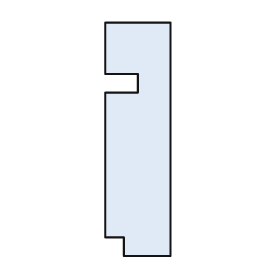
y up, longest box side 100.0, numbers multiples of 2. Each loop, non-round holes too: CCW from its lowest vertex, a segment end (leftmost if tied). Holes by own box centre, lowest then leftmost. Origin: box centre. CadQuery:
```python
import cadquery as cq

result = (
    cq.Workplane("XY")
    .moveTo(-6.0, -50.0)
    .lineTo(14.0, -50.0)
    .lineTo(14.0, 50.0)
    .lineTo(-14.0, 50.0)
    .lineTo(-14.0, 28.0)
    .lineTo(0.0, 28.0)
    .lineTo(0.0, 20.0)
    .lineTo(-14.0, 20.0)
    .lineTo(-14.0, -42.0)
    .lineTo(-6.0, -42.0)
    .close()
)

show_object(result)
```